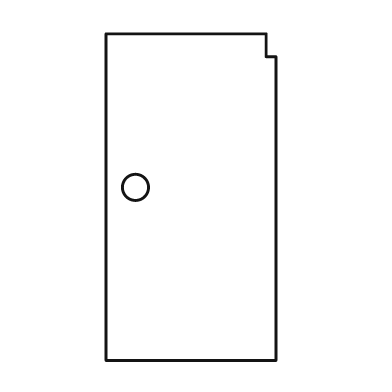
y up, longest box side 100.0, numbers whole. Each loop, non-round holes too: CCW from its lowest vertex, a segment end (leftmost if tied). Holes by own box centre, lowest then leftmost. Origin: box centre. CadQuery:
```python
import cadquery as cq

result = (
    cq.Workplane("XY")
    .moveTo(-26.0, -50.0)
    .lineTo(26.0, -50.0)
    .lineTo(26.0, 43.0)
    .lineTo(23.0, 43.0)
    .lineTo(23.0, 50.0)
    .lineTo(-26.0, 50.0)
    .close()
    .moveTo(-17.0, 3.0)
    .circle(4.0)
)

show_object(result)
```